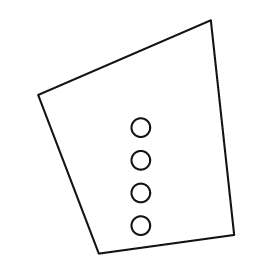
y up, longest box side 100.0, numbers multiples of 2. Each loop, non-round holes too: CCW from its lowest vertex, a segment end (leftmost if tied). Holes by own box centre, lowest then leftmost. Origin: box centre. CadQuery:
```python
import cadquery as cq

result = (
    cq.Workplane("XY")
    .moveTo(-16.0, -50.0)
    .lineTo(42.0, -42.0)
    .lineTo(32.0, 50.0)
    .lineTo(-42.0, 18.0)
    .close()
    .moveTo(2.0, -38.0)
    .circle(4.0)
    .moveTo(2.0, -24.0)
    .circle(4.0)
    .moveTo(2.0, -10.0)
    .circle(4.0)
    .moveTo(2.0, 4.0)
    .circle(4.0)
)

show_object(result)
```